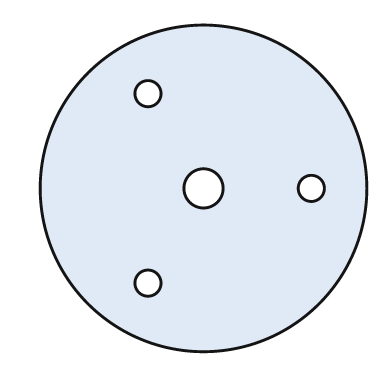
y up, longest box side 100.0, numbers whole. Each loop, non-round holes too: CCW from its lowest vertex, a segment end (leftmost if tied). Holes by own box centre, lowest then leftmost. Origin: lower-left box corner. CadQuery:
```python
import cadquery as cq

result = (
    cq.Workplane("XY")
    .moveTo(50.0, 50.0)
    .circle(50.0)
    .moveTo(33.0, 21.0)
    .circle(4.0)
    .moveTo(50.0, 50.0)
    .circle(6.0)
    .moveTo(83.0, 50.0)
    .circle(4.0)
    .moveTo(33.0, 79.0)
    .circle(4.0)
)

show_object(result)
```